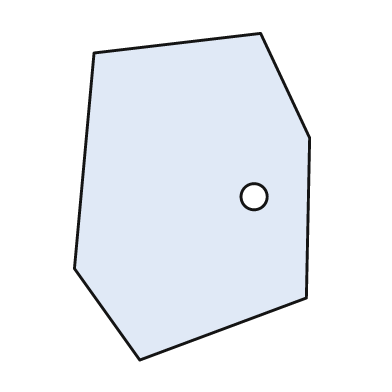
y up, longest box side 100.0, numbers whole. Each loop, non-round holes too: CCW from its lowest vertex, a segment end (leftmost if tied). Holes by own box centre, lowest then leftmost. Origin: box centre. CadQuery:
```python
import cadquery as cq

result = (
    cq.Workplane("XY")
    .moveTo(-16.0, -50.0)
    .lineTo(35.0, -31.0)
    .lineTo(36.0, 18.0)
    .lineTo(21.0, 50.0)
    .lineTo(-30.0, 44.0)
    .lineTo(-36.0, -22.0)
    .close()
    .moveTo(19.0, 0.0)
    .circle(4.0)
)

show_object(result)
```